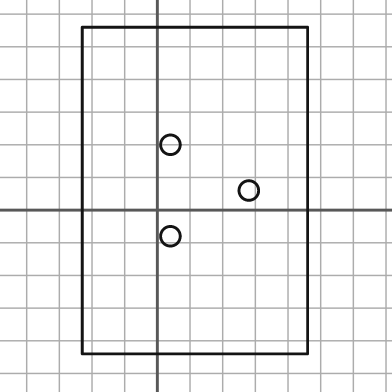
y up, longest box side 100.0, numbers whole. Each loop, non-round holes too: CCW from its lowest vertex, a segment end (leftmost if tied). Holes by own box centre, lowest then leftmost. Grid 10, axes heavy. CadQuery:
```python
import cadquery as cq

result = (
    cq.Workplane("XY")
    .moveTo(-23.0, -44.0)
    .lineTo(46.0, -44.0)
    .lineTo(46.0, 56.0)
    .lineTo(-23.0, 56.0)
    .close()
    .moveTo(4.0, -8.0)
    .circle(3.0)
    .moveTo(28.0, 6.0)
    .circle(3.0)
    .moveTo(4.0, 20.0)
    .circle(3.0)
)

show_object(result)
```